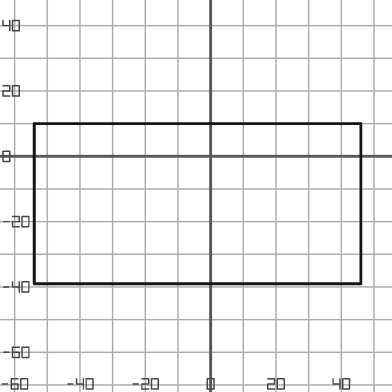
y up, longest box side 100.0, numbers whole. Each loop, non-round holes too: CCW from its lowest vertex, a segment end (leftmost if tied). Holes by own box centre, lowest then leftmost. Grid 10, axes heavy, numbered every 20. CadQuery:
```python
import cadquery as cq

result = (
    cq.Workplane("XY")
    .moveTo(-54.0, -39.0)
    .lineTo(46.0, -39.0)
    .lineTo(46.0, 10.0)
    .lineTo(-54.0, 10.0)
    .close()
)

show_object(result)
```